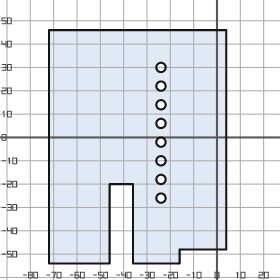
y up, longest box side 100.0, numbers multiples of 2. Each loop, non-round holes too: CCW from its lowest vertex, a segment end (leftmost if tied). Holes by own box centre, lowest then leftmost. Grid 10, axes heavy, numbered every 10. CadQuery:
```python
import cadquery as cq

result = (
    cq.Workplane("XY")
    .moveTo(-72.0, -54.0)
    .lineTo(-46.0, -54.0)
    .lineTo(-46.0, -20.0)
    .lineTo(-36.0, -20.0)
    .lineTo(-36.0, -54.0)
    .lineTo(-16.0, -54.0)
    .lineTo(-16.0, -48.0)
    .lineTo(4.0, -48.0)
    .lineTo(4.0, 46.0)
    .lineTo(-72.0, 46.0)
    .close()
    .moveTo(-24.0, -26.0)
    .circle(2.0)
    .moveTo(-24.0, -18.0)
    .circle(2.0)
    .moveTo(-24.0, -10.0)
    .circle(2.0)
    .moveTo(-24.0, -2.0)
    .circle(2.0)
    .moveTo(-24.0, 6.0)
    .circle(2.0)
    .moveTo(-24.0, 14.0)
    .circle(2.0)
    .moveTo(-24.0, 22.0)
    .circle(2.0)
    .moveTo(-24.0, 30.0)
    .circle(2.0)
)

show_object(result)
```